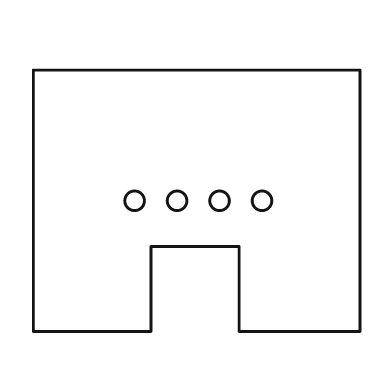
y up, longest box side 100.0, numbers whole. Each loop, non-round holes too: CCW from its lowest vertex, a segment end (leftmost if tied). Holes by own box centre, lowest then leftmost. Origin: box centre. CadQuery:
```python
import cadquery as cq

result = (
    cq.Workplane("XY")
    .moveTo(-50.0, -40.0)
    .lineTo(-14.0, -40.0)
    .lineTo(-14.0, -14.0)
    .lineTo(13.0, -14.0)
    .lineTo(13.0, -40.0)
    .lineTo(50.0, -40.0)
    .lineTo(50.0, 40.0)
    .lineTo(-50.0, 40.0)
    .close()
    .moveTo(-19.0, 0.0)
    .circle(3.0)
    .moveTo(-6.0, 0.0)
    .circle(3.0)
    .moveTo(7.0, 0.0)
    .circle(3.0)
    .moveTo(20.0, 0.0)
    .circle(3.0)
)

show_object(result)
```